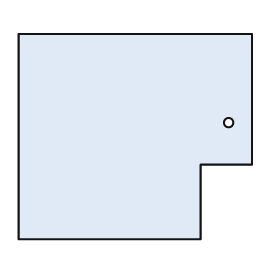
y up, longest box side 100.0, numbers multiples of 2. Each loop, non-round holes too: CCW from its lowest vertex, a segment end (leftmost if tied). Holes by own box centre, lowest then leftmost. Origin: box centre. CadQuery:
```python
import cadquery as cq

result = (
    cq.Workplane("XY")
    .moveTo(-50.0, -44.0)
    .lineTo(28.0, -44.0)
    .lineTo(28.0, -12.0)
    .lineTo(50.0, -12.0)
    .lineTo(50.0, 44.0)
    .lineTo(-50.0, 44.0)
    .close()
    .moveTo(40.0, 6.0)
    .circle(2.0)
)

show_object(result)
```